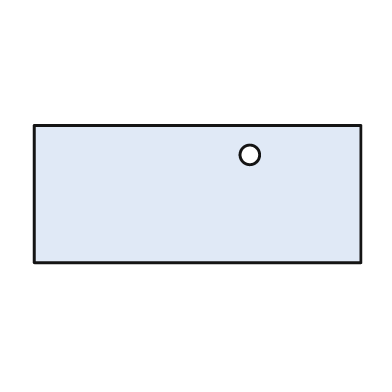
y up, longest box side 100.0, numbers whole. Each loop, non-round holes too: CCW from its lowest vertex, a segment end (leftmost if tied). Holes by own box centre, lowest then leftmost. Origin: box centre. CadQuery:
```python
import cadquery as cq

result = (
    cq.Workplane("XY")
    .moveTo(-50.0, -21.0)
    .lineTo(50.0, -21.0)
    .lineTo(50.0, 21.0)
    .lineTo(-50.0, 21.0)
    .close()
    .moveTo(16.0, 12.0)
    .circle(3.0)
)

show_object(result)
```